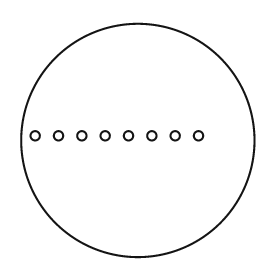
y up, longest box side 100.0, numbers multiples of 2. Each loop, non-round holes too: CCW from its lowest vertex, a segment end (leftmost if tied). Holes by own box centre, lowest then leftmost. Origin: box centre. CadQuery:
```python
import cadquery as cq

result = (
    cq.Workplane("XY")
    .moveTo(0.0, 0.0)
    .circle(50.0)
    .moveTo(-44.0, 2.0)
    .circle(2.0)
    .moveTo(-34.0, 2.0)
    .circle(2.0)
    .moveTo(-24.0, 2.0)
    .circle(2.0)
    .moveTo(-14.0, 2.0)
    .circle(2.0)
    .moveTo(-4.0, 2.0)
    .circle(2.0)
    .moveTo(6.0, 2.0)
    .circle(2.0)
    .moveTo(16.0, 2.0)
    .circle(2.0)
    .moveTo(26.0, 2.0)
    .circle(2.0)
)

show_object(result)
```